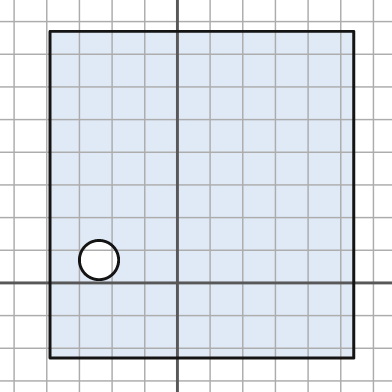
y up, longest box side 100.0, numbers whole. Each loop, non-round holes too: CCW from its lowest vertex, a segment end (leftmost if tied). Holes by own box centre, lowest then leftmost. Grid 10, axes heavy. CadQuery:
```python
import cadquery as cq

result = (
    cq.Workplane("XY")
    .moveTo(-39.0, -23.0)
    .lineTo(54.0, -23.0)
    .lineTo(54.0, 77.0)
    .lineTo(-39.0, 77.0)
    .close()
    .moveTo(-24.0, 7.0)
    .circle(6.0)
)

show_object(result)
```